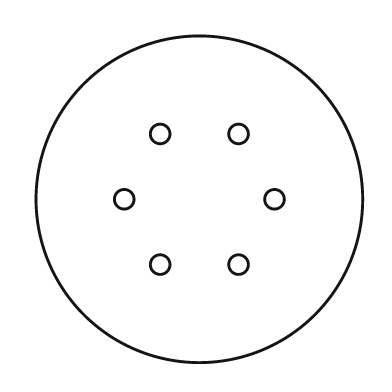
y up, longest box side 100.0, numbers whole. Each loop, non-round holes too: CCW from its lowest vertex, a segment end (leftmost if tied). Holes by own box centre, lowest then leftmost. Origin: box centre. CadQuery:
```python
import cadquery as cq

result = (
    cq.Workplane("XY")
    .moveTo(0.0, 0.0)
    .circle(50.0)
    .moveTo(-12.0, -20.0)
    .circle(3.0)
    .moveTo(12.0, -20.0)
    .circle(3.0)
    .moveTo(-23.0, 0.0)
    .circle(3.0)
    .moveTo(23.0, 0.0)
    .circle(3.0)
    .moveTo(-12.0, 20.0)
    .circle(3.0)
    .moveTo(12.0, 20.0)
    .circle(3.0)
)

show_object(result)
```